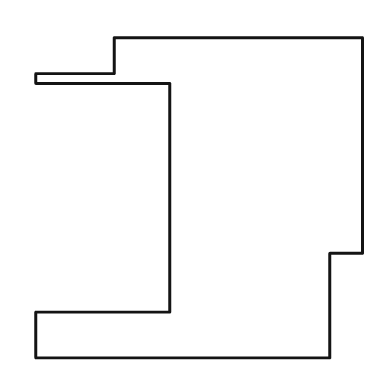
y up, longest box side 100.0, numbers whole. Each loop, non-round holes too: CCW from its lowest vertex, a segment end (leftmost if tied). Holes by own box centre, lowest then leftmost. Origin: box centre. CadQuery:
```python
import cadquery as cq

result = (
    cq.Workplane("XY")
    .moveTo(-50.0, -49.0)
    .lineTo(40.0, -49.0)
    .lineTo(40.0, -17.0)
    .lineTo(50.0, -17.0)
    .lineTo(50.0, 49.0)
    .lineTo(-26.0, 49.0)
    .lineTo(-26.0, 38.0)
    .lineTo(-50.0, 38.0)
    .lineTo(-50.0, 35.0)
    .lineTo(-9.0, 35.0)
    .lineTo(-9.0, -35.0)
    .lineTo(-50.0, -35.0)
    .close()
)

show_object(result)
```